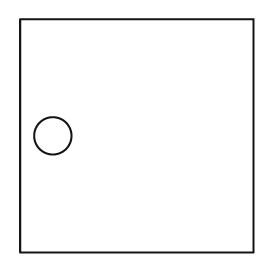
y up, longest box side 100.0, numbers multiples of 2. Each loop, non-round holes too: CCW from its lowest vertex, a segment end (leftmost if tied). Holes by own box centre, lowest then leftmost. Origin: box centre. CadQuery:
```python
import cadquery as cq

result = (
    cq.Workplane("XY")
    .moveTo(-50.0, -50.0)
    .lineTo(50.0, -50.0)
    .lineTo(50.0, 50.0)
    .lineTo(-50.0, 50.0)
    .close()
    .moveTo(-36.0, 0.0)
    .circle(8.0)
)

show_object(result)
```